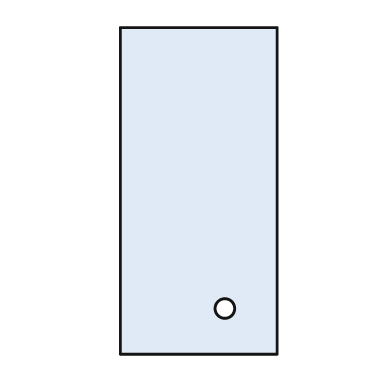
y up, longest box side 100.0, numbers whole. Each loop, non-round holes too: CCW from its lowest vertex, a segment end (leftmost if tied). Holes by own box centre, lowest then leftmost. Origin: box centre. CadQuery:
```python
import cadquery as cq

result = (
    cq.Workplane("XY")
    .moveTo(-24.0, -50.0)
    .lineTo(24.0, -50.0)
    .lineTo(24.0, 50.0)
    .lineTo(-24.0, 50.0)
    .close()
    .moveTo(8.0, -36.0)
    .circle(3.0)
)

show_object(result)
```